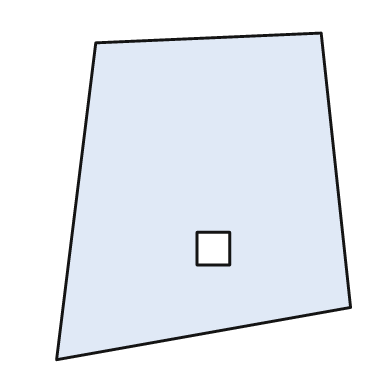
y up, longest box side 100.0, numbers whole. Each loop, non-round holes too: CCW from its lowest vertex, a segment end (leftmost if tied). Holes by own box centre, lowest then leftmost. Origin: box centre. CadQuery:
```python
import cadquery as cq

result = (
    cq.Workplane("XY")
    .moveTo(-45.0, -50.0)
    .lineTo(45.0, -34.0)
    .lineTo(36.0, 50.0)
    .lineTo(-33.0, 47.0)
    .close()
    .moveTo(-2.0, -21.0)
    .lineTo(8.0, -21.0)
    .lineTo(8.0, -11.0)
    .lineTo(-2.0, -11.0)
    .close()
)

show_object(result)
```